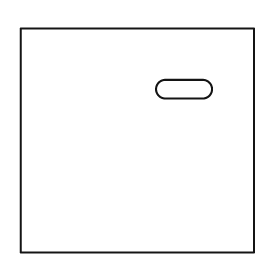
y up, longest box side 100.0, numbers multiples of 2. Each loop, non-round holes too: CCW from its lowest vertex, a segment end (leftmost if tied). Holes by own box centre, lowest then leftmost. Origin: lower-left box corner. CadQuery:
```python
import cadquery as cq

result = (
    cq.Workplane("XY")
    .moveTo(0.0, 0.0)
    .lineTo(100.0, 0.0)
    .lineTo(100.0, 96.0)
    .lineTo(0.0, 96.0)
    .close()
    .moveTo(62.0, 66.0)
    .lineTo(78.0, 66.0)
    .threePointArc((82.0, 70.0), (78.0, 74.0))
    .lineTo(62.0, 74.0)
    .threePointArc((58.0, 70.0), (62.0, 66.0))
    .close()
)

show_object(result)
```